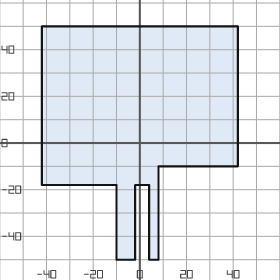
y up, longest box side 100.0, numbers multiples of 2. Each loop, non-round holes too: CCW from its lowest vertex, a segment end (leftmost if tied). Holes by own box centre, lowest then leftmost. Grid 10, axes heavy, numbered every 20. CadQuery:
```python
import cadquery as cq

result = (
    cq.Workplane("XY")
    .moveTo(-10.0, -50.0)
    .lineTo(-2.0, -50.0)
    .lineTo(-2.0, -18.0)
    .lineTo(4.0, -18.0)
    .lineTo(4.0, -50.0)
    .lineTo(8.0, -50.0)
    .lineTo(8.0, -10.0)
    .lineTo(42.0, -10.0)
    .lineTo(42.0, 50.0)
    .lineTo(-42.0, 50.0)
    .lineTo(-42.0, -18.0)
    .lineTo(-10.0, -18.0)
    .close()
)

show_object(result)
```